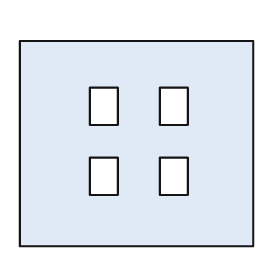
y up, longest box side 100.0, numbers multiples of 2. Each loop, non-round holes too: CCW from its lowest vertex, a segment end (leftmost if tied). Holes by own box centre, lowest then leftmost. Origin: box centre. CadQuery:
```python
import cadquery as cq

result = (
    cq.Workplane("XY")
    .moveTo(-50.0, -44.0)
    .lineTo(50.0, -44.0)
    .lineTo(50.0, 44.0)
    .lineTo(-50.0, 44.0)
    .close()
    .moveTo(-20.0, -22.0)
    .lineTo(-8.0, -22.0)
    .lineTo(-8.0, -6.0)
    .lineTo(-20.0, -6.0)
    .close()
    .moveTo(10.0, -22.0)
    .lineTo(22.0, -22.0)
    .lineTo(22.0, -6.0)
    .lineTo(10.0, -6.0)
    .close()
    .moveTo(-20.0, 8.0)
    .lineTo(-8.0, 8.0)
    .lineTo(-8.0, 24.0)
    .lineTo(-20.0, 24.0)
    .close()
    .moveTo(10.0, 8.0)
    .lineTo(22.0, 8.0)
    .lineTo(22.0, 24.0)
    .lineTo(10.0, 24.0)
    .close()
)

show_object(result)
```